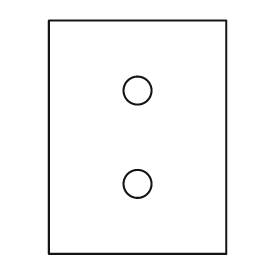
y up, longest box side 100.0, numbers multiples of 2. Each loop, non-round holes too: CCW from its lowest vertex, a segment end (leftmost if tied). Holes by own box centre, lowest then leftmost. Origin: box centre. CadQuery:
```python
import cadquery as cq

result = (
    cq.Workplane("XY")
    .moveTo(-38.0, -50.0)
    .lineTo(38.0, -50.0)
    .lineTo(38.0, 50.0)
    .lineTo(-38.0, 50.0)
    .close()
    .moveTo(0.0, -20.0)
    .circle(6.0)
    .moveTo(0.0, 20.0)
    .circle(6.0)
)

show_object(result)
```